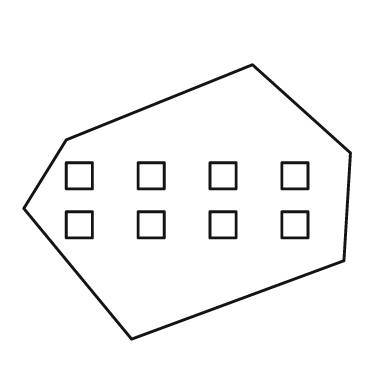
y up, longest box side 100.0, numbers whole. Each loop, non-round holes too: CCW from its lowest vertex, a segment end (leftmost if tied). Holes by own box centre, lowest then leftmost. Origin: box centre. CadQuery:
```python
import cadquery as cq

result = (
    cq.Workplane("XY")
    .moveTo(-17.0, -42.0)
    .lineTo(48.0, -18.0)
    .lineTo(50.0, 15.0)
    .lineTo(20.0, 42.0)
    .lineTo(-37.0, 19.0)
    .lineTo(-50.0, -2.0)
    .close()
    .moveTo(-37.0, -11.0)
    .lineTo(-29.0, -11.0)
    .lineTo(-29.0, -3.0)
    .lineTo(-37.0, -3.0)
    .close()
    .moveTo(-15.0, -11.0)
    .lineTo(-7.0, -11.0)
    .lineTo(-7.0, -3.0)
    .lineTo(-15.0, -3.0)
    .close()
    .moveTo(7.0, -11.0)
    .lineTo(15.0, -11.0)
    .lineTo(15.0, -3.0)
    .lineTo(7.0, -3.0)
    .close()
    .moveTo(29.0, -11.0)
    .lineTo(37.0, -11.0)
    .lineTo(37.0, -3.0)
    .lineTo(29.0, -3.0)
    .close()
    .moveTo(-37.0, 4.0)
    .lineTo(-29.0, 4.0)
    .lineTo(-29.0, 12.0)
    .lineTo(-37.0, 12.0)
    .close()
    .moveTo(-15.0, 4.0)
    .lineTo(-7.0, 4.0)
    .lineTo(-7.0, 12.0)
    .lineTo(-15.0, 12.0)
    .close()
    .moveTo(7.0, 4.0)
    .lineTo(15.0, 4.0)
    .lineTo(15.0, 12.0)
    .lineTo(7.0, 12.0)
    .close()
    .moveTo(29.0, 4.0)
    .lineTo(37.0, 4.0)
    .lineTo(37.0, 12.0)
    .lineTo(29.0, 12.0)
    .close()
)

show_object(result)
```